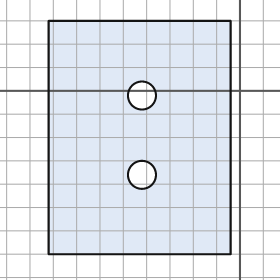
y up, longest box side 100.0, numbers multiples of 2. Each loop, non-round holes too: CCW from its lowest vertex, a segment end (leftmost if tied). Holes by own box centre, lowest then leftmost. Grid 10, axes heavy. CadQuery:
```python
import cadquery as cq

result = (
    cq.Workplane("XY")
    .moveTo(-82.0, -70.0)
    .lineTo(-4.0, -70.0)
    .lineTo(-4.0, 30.0)
    .lineTo(-82.0, 30.0)
    .close()
    .moveTo(-42.0, -36.0)
    .circle(6.0)
    .moveTo(-42.0, -2.0)
    .circle(6.0)
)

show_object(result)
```